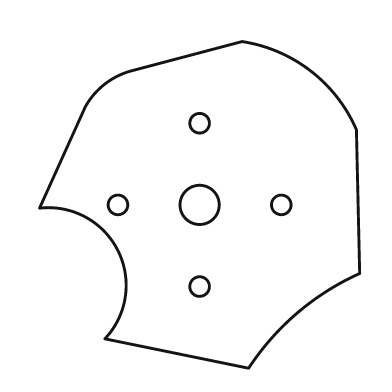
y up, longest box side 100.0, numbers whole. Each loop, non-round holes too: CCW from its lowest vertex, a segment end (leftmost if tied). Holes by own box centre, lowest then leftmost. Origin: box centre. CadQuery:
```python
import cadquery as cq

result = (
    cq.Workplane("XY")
    .moveTo(15.0, -50.0)
    .threePointArc((30.0, -33.0), (49.0, -21.0))
    .lineTo(48.0, 23.0)
    .threePointArc((34.0, 41.0), (13.0, 50.0))
    .lineTo(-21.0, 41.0)
    .threePointArc((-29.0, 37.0), (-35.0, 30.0))
    .lineTo(-49.0, -1.0)
    .threePointArc((-25.0, -14.0), (-29.0, -41.0))
    .close()
    .moveTo(0.0, -25.0)
    .circle(3.0)
    .moveTo(-25.0, 0.0)
    .circle(3.0)
    .moveTo(0.0, 0.0)
    .circle(6.0)
    .moveTo(25.0, 0.0)
    .circle(3.0)
    .moveTo(0.0, 25.0)
    .circle(3.0)
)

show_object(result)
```